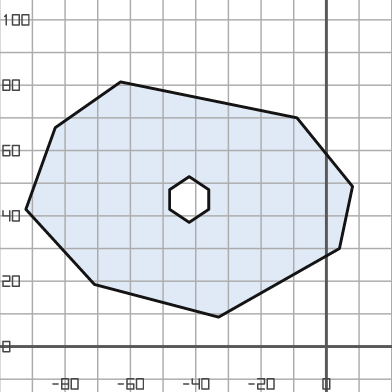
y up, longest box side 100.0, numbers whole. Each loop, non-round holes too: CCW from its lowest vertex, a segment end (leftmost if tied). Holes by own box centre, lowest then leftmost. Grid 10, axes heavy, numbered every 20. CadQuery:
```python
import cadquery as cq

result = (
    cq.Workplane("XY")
    .moveTo(-33.0, 9.0)
    .lineTo(4.0, 30.0)
    .lineTo(8.0, 49.0)
    .lineTo(-9.0, 70.0)
    .lineTo(-63.0, 81.0)
    .lineTo(-83.0, 67.0)
    .lineTo(-92.0, 42.0)
    .lineTo(-71.0, 19.0)
    .close()
    .moveTo(-42.0, 38.0)
    .lineTo(-36.0, 42.0)
    .lineTo(-36.0, 48.0)
    .lineTo(-42.0, 52.0)
    .lineTo(-48.0, 48.0)
    .lineTo(-48.0, 42.0)
    .close()
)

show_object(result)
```